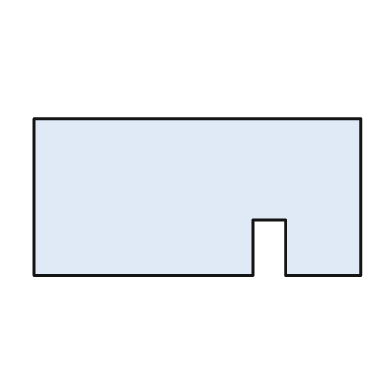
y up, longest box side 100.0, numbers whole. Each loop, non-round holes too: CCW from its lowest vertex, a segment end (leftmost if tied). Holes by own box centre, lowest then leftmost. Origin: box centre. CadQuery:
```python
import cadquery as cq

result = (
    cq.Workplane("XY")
    .moveTo(-50.0, -24.0)
    .lineTo(17.0, -24.0)
    .lineTo(17.0, -7.0)
    .lineTo(27.0, -7.0)
    .lineTo(27.0, -24.0)
    .lineTo(50.0, -24.0)
    .lineTo(50.0, 24.0)
    .lineTo(-50.0, 24.0)
    .close()
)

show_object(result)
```